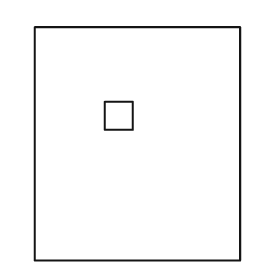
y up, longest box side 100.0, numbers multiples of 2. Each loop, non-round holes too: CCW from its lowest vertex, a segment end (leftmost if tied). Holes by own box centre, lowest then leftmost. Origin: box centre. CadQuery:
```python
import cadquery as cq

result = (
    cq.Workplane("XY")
    .moveTo(-44.0, -50.0)
    .lineTo(44.0, -50.0)
    .lineTo(44.0, 50.0)
    .lineTo(-44.0, 50.0)
    .close()
    .moveTo(-14.0, 6.0)
    .lineTo(-2.0, 6.0)
    .lineTo(-2.0, 18.0)
    .lineTo(-14.0, 18.0)
    .close()
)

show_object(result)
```